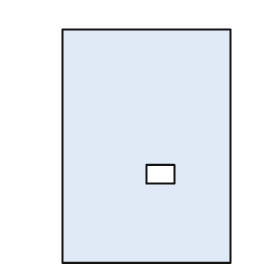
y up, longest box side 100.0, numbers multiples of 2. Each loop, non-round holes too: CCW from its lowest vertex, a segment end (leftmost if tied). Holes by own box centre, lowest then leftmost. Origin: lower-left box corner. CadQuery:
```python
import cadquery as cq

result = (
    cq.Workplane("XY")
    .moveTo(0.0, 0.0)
    .lineTo(72.0, 0.0)
    .lineTo(72.0, 100.0)
    .lineTo(0.0, 100.0)
    .close()
    .moveTo(36.0, 34.0)
    .lineTo(48.0, 34.0)
    .lineTo(48.0, 42.0)
    .lineTo(36.0, 42.0)
    .close()
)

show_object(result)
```